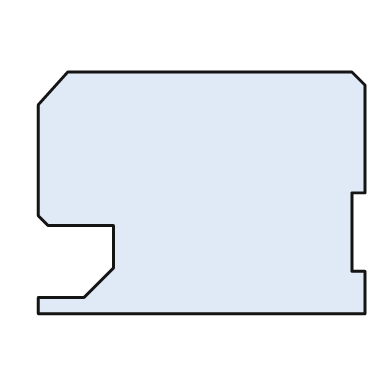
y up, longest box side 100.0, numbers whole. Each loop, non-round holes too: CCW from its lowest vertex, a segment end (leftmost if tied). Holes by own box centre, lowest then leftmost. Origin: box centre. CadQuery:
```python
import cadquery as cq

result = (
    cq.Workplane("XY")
    .moveTo(-50.0, -37.0)
    .lineTo(50.0, -37.0)
    .lineTo(50.0, -24.0)
    .lineTo(46.0, -24.0)
    .lineTo(46.0, 0.0)
    .lineTo(50.0, 0.0)
    .lineTo(50.0, 33.0)
    .lineTo(46.0, 37.0)
    .lineTo(-41.0, 37.0)
    .lineTo(-50.0, 27.0)
    .lineTo(-50.0, -7.0)
    .lineTo(-47.0, -10.0)
    .lineTo(-27.0, -10.0)
    .lineTo(-27.0, -23.0)
    .lineTo(-36.0, -32.0)
    .lineTo(-50.0, -32.0)
    .close()
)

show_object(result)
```